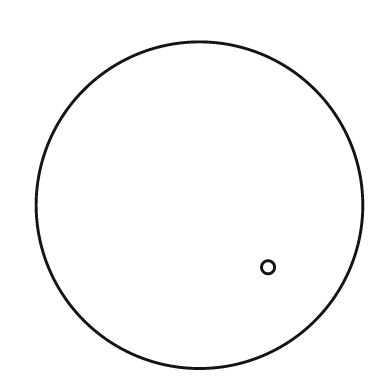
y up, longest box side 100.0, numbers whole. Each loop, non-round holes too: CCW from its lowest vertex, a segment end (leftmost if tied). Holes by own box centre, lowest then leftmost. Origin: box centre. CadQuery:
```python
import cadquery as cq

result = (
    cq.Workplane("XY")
    .moveTo(0.0, 0.0)
    .circle(50.0)
    .moveTo(21.0, -19.0)
    .circle(2.0)
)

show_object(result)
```